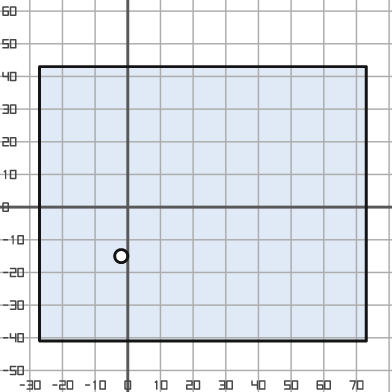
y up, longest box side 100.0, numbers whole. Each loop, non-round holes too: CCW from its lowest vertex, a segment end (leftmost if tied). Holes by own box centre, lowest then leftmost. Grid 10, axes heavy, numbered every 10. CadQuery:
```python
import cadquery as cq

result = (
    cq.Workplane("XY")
    .moveTo(-27.0, -41.0)
    .lineTo(73.0, -41.0)
    .lineTo(73.0, 43.0)
    .lineTo(-27.0, 43.0)
    .close()
    .moveTo(-2.0, -15.0)
    .circle(2.0)
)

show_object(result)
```